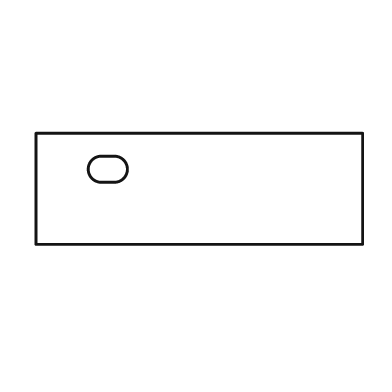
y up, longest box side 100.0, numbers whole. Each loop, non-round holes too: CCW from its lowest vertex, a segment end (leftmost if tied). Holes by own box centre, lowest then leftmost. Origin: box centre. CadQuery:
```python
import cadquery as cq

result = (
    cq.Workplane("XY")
    .moveTo(-50.0, -17.0)
    .lineTo(50.0, -17.0)
    .lineTo(50.0, 17.0)
    .lineTo(-50.0, 17.0)
    .close()
    .moveTo(-30.0, 2.0)
    .lineTo(-26.0, 2.0)
    .threePointArc((-22.0, 6.0), (-26.0, 10.0))
    .lineTo(-30.0, 10.0)
    .threePointArc((-34.0, 6.0), (-30.0, 2.0))
    .close()
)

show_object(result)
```